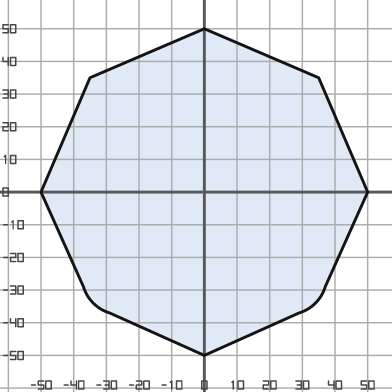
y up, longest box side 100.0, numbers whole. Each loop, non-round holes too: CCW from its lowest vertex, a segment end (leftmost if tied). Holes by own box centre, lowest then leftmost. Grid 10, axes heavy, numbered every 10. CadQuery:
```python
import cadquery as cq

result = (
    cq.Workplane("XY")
    .moveTo(0.0, -50.0)
    .lineTo(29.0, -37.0)
    .threePointArc((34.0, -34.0), (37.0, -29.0))
    .lineTo(50.0, 0.0)
    .lineTo(35.0, 35.0)
    .lineTo(0.0, 50.0)
    .lineTo(-35.0, 35.0)
    .lineTo(-50.0, 0.0)
    .lineTo(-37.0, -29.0)
    .threePointArc((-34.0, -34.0), (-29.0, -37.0))
    .close()
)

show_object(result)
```